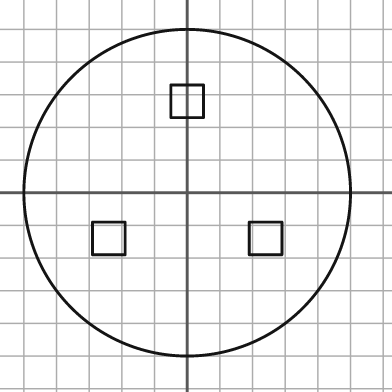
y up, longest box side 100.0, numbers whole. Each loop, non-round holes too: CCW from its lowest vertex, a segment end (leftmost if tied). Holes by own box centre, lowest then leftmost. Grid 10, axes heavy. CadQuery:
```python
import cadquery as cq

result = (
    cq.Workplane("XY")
    .moveTo(0.0, 0.0)
    .circle(50.0)
    .moveTo(-29.0, -19.0)
    .lineTo(-19.0, -19.0)
    .lineTo(-19.0, -9.0)
    .lineTo(-29.0, -9.0)
    .close()
    .moveTo(19.0, -19.0)
    .lineTo(29.0, -19.0)
    .lineTo(29.0, -9.0)
    .lineTo(19.0, -9.0)
    .close()
    .moveTo(-5.0, 23.0)
    .lineTo(5.0, 23.0)
    .lineTo(5.0, 33.0)
    .lineTo(-5.0, 33.0)
    .close()
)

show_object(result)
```